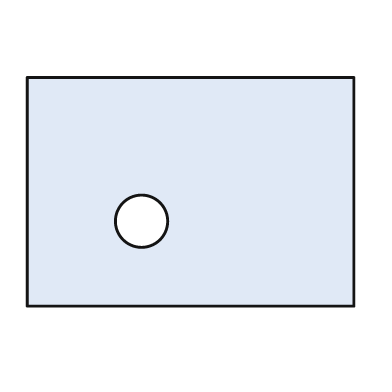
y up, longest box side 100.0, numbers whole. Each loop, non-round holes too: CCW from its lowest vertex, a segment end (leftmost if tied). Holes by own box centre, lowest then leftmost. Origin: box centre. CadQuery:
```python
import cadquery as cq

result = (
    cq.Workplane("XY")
    .moveTo(-50.0, -35.0)
    .lineTo(50.0, -35.0)
    .lineTo(50.0, 35.0)
    .lineTo(-50.0, 35.0)
    .close()
    .moveTo(-15.0, -9.0)
    .circle(8.0)
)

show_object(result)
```